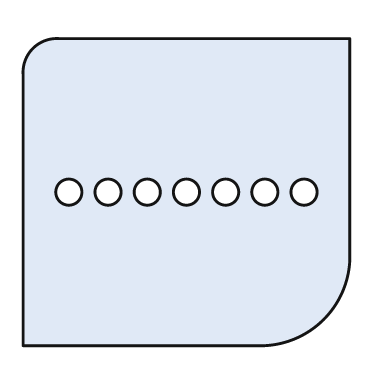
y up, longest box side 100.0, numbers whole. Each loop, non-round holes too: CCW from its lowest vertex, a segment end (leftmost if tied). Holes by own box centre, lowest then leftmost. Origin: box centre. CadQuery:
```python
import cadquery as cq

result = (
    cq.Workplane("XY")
    .moveTo(-50.0, -47.0)
    .lineTo(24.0, -47.0)
    .threePointArc((42.0, -39.0), (50.0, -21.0))
    .lineTo(50.0, 47.0)
    .lineTo(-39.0, 47.0)
    .threePointArc((-47.0, 44.0), (-50.0, 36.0))
    .close()
    .moveTo(-36.0, 0.0)
    .circle(4.0)
    .moveTo(-24.0, 0.0)
    .circle(4.0)
    .moveTo(-12.0, 0.0)
    .circle(4.0)
    .moveTo(0.0, 0.0)
    .circle(4.0)
    .moveTo(12.0, 0.0)
    .circle(4.0)
    .moveTo(24.0, 0.0)
    .circle(4.0)
    .moveTo(36.0, 0.0)
    .circle(4.0)
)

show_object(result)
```